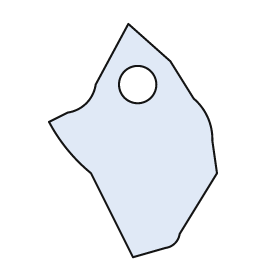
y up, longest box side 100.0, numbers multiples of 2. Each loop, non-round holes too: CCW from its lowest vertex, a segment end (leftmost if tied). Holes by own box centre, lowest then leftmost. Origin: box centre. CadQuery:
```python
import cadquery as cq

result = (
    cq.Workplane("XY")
    .moveTo(0.0, -50.0)
    .lineTo(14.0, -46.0)
    .threePointArc((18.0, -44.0), (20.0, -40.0))
    .lineTo(36.0, -14.0)
    .lineTo(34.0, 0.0)
    .threePointArc((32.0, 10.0), (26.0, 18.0))
    .lineTo(16.0, 34.0)
    .lineTo(-2.0, 50.0)
    .lineTo(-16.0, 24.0)
    .threePointArc((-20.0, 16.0), (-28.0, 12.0))
    .lineTo(-36.0, 8.0)
    .threePointArc((-28.0, -4.0), (-18.0, -14.0))
    .close()
    .moveTo(2.0, 24.0)
    .circle(8.0)
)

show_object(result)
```